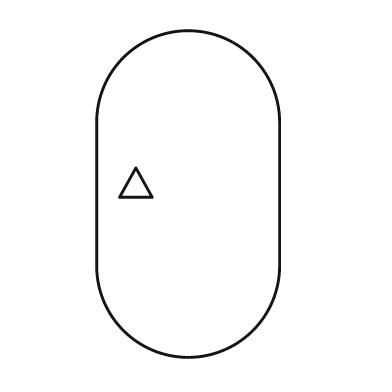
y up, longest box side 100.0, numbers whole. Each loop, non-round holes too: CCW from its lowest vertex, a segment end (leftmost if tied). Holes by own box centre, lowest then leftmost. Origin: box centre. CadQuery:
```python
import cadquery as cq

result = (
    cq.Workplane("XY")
    .moveTo(-28.0, -22.0)
    .threePointArc((0.0, -50.0), (28.0, -22.0))
    .lineTo(28.0, 22.0)
    .threePointArc((0.0, 50.0), (-28.0, 22.0))
    .close()
    .moveTo(-21.0, -1.0)
    .lineTo(-11.0, -1.0)
    .lineTo(-16.0, 8.0)
    .close()
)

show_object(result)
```